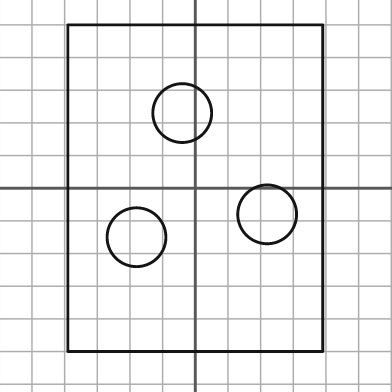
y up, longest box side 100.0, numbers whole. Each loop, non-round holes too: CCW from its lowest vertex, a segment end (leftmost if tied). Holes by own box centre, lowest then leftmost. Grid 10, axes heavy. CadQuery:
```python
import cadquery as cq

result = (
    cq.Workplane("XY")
    .moveTo(-39.0, -50.0)
    .lineTo(39.0, -50.0)
    .lineTo(39.0, 50.0)
    .lineTo(-39.0, 50.0)
    .close()
    .moveTo(-18.0, -15.0)
    .circle(9.0)
    .moveTo(22.0, -8.0)
    .circle(9.0)
    .moveTo(-4.0, 23.0)
    .circle(9.0)
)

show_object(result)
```